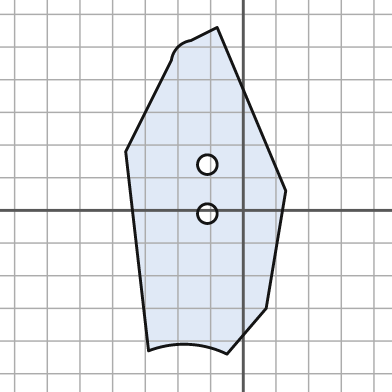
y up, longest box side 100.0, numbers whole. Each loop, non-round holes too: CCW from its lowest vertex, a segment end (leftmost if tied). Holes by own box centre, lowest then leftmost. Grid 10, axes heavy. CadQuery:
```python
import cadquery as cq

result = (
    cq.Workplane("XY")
    .moveTo(-5.0, -44.0)
    .lineTo(7.0, -30.0)
    .lineTo(13.0, 6.0)
    .lineTo(-8.0, 56.0)
    .lineTo(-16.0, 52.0)
    .threePointArc((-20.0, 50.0), (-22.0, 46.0))
    .lineTo(-36.0, 18.0)
    .lineTo(-29.0, -43.0)
    .threePointArc((-17.0, -41.0), (-5.0, -44.0))
    .close()
    .moveTo(-11.0, -1.0)
    .circle(3.0)
    .moveTo(-11.0, 14.0)
    .circle(3.0)
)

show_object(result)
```